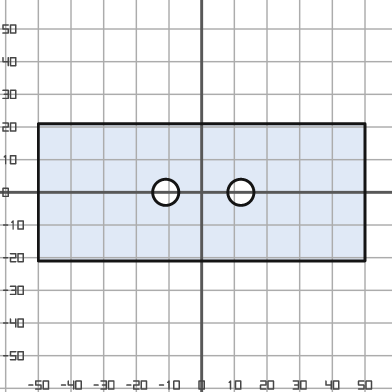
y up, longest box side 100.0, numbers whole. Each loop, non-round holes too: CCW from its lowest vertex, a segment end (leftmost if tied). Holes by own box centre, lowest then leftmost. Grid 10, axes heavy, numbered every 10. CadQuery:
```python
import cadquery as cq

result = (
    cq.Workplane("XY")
    .moveTo(-50.0, -21.0)
    .lineTo(50.0, -21.0)
    .lineTo(50.0, 21.0)
    .lineTo(-50.0, 21.0)
    .close()
    .moveTo(-11.0, 0.0)
    .circle(4.0)
    .moveTo(12.0, 0.0)
    .circle(4.0)
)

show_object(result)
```